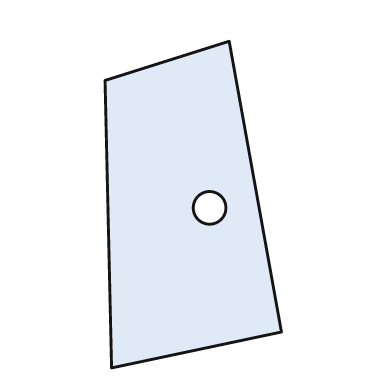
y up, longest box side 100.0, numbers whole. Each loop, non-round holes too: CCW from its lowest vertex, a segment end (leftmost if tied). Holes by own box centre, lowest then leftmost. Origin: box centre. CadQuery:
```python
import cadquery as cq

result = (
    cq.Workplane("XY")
    .moveTo(-25.0, -50.0)
    .lineTo(27.0, -39.0)
    .lineTo(11.0, 50.0)
    .lineTo(-27.0, 38.0)
    .close()
    .moveTo(5.0, -1.0)
    .circle(5.0)
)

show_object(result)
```